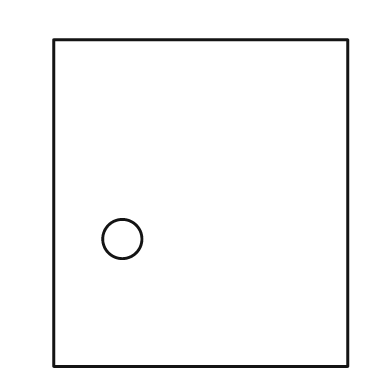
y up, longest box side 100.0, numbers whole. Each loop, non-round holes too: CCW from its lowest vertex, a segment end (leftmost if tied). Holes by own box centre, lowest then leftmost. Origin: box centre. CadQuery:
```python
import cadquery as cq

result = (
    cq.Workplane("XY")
    .moveTo(-45.0, -50.0)
    .lineTo(45.0, -50.0)
    .lineTo(45.0, 50.0)
    .lineTo(-45.0, 50.0)
    .close()
    .moveTo(-24.0, -11.0)
    .circle(6.0)
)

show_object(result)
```